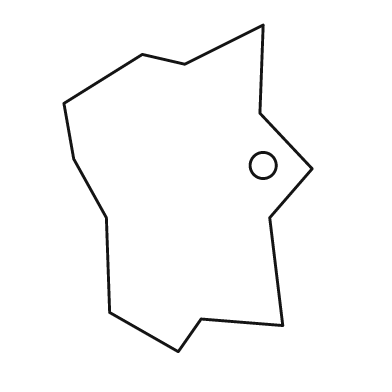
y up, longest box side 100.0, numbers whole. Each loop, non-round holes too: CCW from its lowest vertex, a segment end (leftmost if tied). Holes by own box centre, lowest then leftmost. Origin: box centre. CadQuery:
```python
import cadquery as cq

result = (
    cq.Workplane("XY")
    .moveTo(-3.0, -50.0)
    .lineTo(4.0, -40.0)
    .lineTo(29.0, -42.0)
    .lineTo(25.0, -9.0)
    .lineTo(38.0, 6.0)
    .lineTo(22.0, 23.0)
    .lineTo(23.0, 50.0)
    .lineTo(-1.0, 38.0)
    .lineTo(-14.0, 41.0)
    .lineTo(-38.0, 26.0)
    .lineTo(-35.0, 9.0)
    .lineTo(-25.0, -9.0)
    .lineTo(-24.0, -38.0)
    .close()
    .moveTo(23.0, 7.0)
    .circle(4.0)
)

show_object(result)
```